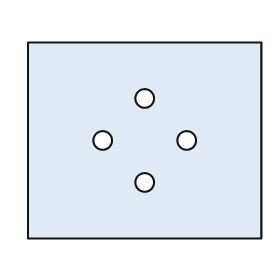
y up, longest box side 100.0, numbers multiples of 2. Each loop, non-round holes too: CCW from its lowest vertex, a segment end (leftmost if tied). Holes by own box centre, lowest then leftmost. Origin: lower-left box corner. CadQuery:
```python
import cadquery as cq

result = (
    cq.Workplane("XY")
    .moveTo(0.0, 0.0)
    .lineTo(100.0, 0.0)
    .lineTo(100.0, 84.0)
    .lineTo(0.0, 84.0)
    .close()
    .moveTo(50.0, 24.0)
    .circle(4.0)
    .moveTo(32.0, 42.0)
    .circle(4.0)
    .moveTo(68.0, 42.0)
    .circle(4.0)
    .moveTo(50.0, 60.0)
    .circle(4.0)
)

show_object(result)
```